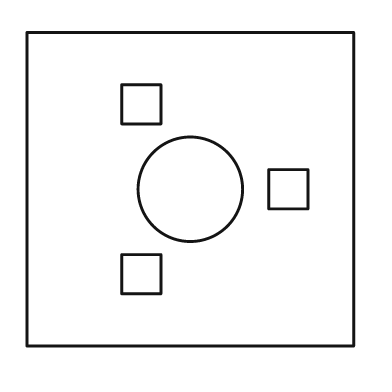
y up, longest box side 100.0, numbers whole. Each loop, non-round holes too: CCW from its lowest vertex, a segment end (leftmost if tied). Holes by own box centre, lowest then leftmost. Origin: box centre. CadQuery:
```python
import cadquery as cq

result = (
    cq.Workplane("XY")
    .moveTo(-50.0, -48.0)
    .lineTo(50.0, -48.0)
    .lineTo(50.0, 48.0)
    .lineTo(-50.0, 48.0)
    .close()
    .moveTo(-21.0, -32.0)
    .lineTo(-9.0, -32.0)
    .lineTo(-9.0, -20.0)
    .lineTo(-21.0, -20.0)
    .close()
    .moveTo(0.0, 0.0)
    .circle(16.0)
    .moveTo(24.0, -6.0)
    .lineTo(36.0, -6.0)
    .lineTo(36.0, 6.0)
    .lineTo(24.0, 6.0)
    .close()
    .moveTo(-21.0, 20.0)
    .lineTo(-9.0, 20.0)
    .lineTo(-9.0, 32.0)
    .lineTo(-21.0, 32.0)
    .close()
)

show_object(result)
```